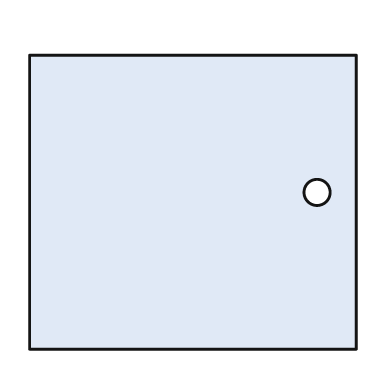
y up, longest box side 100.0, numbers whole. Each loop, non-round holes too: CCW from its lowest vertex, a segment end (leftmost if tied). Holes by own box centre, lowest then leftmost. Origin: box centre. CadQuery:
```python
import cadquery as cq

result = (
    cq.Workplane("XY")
    .moveTo(-50.0, -45.0)
    .lineTo(50.0, -45.0)
    .lineTo(50.0, 45.0)
    .lineTo(-50.0, 45.0)
    .close()
    .moveTo(38.0, 3.0)
    .circle(4.0)
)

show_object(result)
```